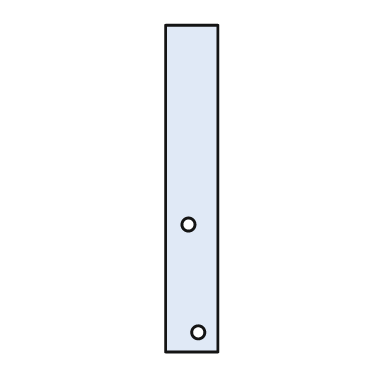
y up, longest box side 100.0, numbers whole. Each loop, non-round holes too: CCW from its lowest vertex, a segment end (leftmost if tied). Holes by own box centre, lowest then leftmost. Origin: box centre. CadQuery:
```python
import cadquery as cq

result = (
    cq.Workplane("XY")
    .moveTo(-8.0, -50.0)
    .lineTo(8.0, -50.0)
    .lineTo(8.0, 50.0)
    .lineTo(-8.0, 50.0)
    .close()
    .moveTo(2.0, -44.0)
    .circle(2.0)
    .moveTo(-1.0, -11.0)
    .circle(2.0)
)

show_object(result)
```